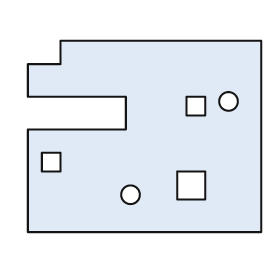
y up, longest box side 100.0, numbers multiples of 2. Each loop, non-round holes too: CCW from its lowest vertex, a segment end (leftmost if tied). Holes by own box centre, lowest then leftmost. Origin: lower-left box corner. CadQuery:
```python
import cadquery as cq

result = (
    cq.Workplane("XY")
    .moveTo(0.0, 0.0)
    .lineTo(100.0, 0.0)
    .lineTo(100.0, 82.0)
    .lineTo(14.0, 82.0)
    .lineTo(14.0, 72.0)
    .lineTo(0.0, 72.0)
    .lineTo(0.0, 58.0)
    .lineTo(42.0, 58.0)
    .lineTo(42.0, 44.0)
    .lineTo(0.0, 44.0)
    .close()
    .moveTo(44.0, 16.0)
    .circle(4.0)
    .moveTo(64.0, 14.0)
    .lineTo(76.0, 14.0)
    .lineTo(76.0, 26.0)
    .lineTo(64.0, 26.0)
    .close()
    .moveTo(6.0, 26.0)
    .lineTo(14.0, 26.0)
    .lineTo(14.0, 34.0)
    .lineTo(6.0, 34.0)
    .close()
    .moveTo(68.0, 50.0)
    .lineTo(76.0, 50.0)
    .lineTo(76.0, 58.0)
    .lineTo(68.0, 58.0)
    .close()
    .moveTo(86.0, 56.0)
    .circle(4.0)
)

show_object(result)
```